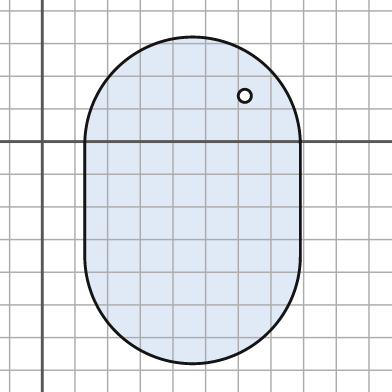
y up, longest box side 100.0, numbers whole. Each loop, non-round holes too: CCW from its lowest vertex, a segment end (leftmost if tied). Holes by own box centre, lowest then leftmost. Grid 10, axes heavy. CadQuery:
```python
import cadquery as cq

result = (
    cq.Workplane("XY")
    .moveTo(13.0, -35.0)
    .threePointArc((46.0, -68.0), (79.0, -35.0))
    .lineTo(79.0, -1.0)
    .threePointArc((46.0, 32.0), (13.0, -1.0))
    .close()
    .moveTo(62.0, 14.0)
    .circle(2.0)
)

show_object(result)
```